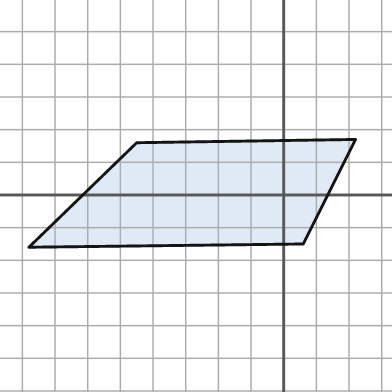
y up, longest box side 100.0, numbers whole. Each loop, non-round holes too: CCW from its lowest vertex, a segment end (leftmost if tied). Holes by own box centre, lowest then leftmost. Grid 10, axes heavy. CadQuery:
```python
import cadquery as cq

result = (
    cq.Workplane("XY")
    .moveTo(-78.0, -16.0)
    .lineTo(6.0, -15.0)
    .lineTo(22.0, 17.0)
    .lineTo(-45.0, 16.0)
    .close()
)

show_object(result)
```